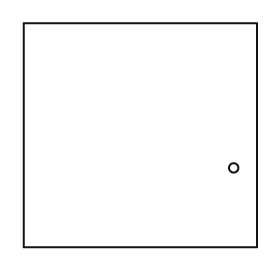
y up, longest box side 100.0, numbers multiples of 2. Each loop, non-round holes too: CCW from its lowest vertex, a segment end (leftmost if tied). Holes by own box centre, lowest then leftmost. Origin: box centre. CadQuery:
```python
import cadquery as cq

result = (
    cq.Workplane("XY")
    .moveTo(-50.0, -48.0)
    .lineTo(50.0, -48.0)
    .lineTo(50.0, 48.0)
    .lineTo(-50.0, 48.0)
    .close()
    .moveTo(40.0, -14.0)
    .circle(2.0)
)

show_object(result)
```